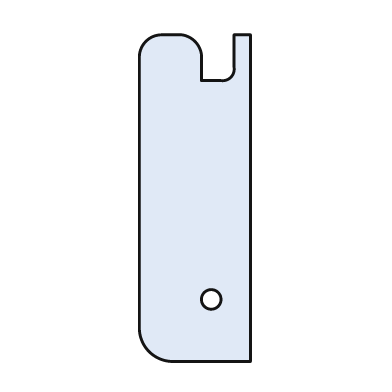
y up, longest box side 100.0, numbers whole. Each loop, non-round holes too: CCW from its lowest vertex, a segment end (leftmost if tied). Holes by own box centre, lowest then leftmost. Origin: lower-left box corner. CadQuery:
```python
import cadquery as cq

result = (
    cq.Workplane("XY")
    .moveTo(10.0, 0.0)
    .lineTo(34.0, 0.0)
    .lineTo(34.0, 100.0)
    .lineTo(29.0, 100.0)
    .lineTo(29.0, 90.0)
    .threePointArc((28.0, 87.0), (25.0, 86.0))
    .lineTo(19.0, 86.0)
    .lineTo(19.0, 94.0)
    .threePointArc((17.0, 98.0), (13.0, 100.0))
    .lineTo(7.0, 100.0)
    .threePointArc((2.0, 98.0), (0.0, 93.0))
    .lineTo(0.0, 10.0)
    .threePointArc((3.0, 3.0), (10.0, 0.0))
    .close()
    .moveTo(22.0, 19.0)
    .circle(3.0)
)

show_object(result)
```